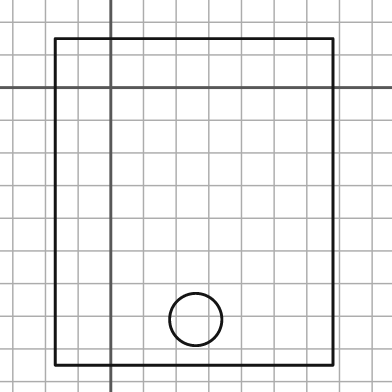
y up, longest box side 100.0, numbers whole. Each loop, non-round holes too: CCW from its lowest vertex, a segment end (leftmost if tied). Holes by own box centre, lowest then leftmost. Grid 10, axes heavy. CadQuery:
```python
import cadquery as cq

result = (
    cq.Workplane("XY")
    .moveTo(-17.0, -85.0)
    .lineTo(68.0, -85.0)
    .lineTo(68.0, 15.0)
    .lineTo(-17.0, 15.0)
    .close()
    .moveTo(26.0, -71.0)
    .circle(8.0)
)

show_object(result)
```